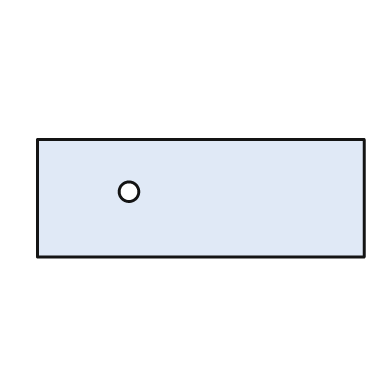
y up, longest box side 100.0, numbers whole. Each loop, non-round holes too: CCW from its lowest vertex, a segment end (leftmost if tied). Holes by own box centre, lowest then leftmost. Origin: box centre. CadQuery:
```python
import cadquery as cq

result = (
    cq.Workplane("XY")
    .moveTo(-50.0, -18.0)
    .lineTo(50.0, -18.0)
    .lineTo(50.0, 18.0)
    .lineTo(-50.0, 18.0)
    .close()
    .moveTo(-22.0, 2.0)
    .circle(3.0)
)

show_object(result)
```